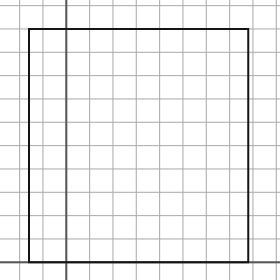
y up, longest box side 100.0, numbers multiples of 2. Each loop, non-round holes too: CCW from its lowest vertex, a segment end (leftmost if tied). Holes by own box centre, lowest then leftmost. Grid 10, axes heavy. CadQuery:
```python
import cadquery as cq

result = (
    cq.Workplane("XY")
    .moveTo(-16.0, 0.0)
    .lineTo(78.0, 0.0)
    .lineTo(78.0, 100.0)
    .lineTo(-16.0, 100.0)
    .close()
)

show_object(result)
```